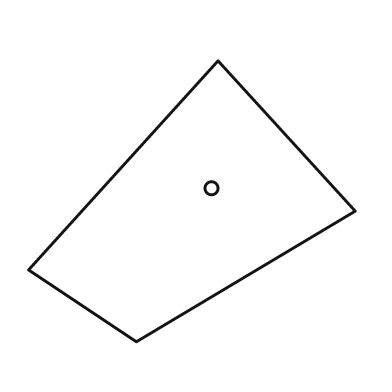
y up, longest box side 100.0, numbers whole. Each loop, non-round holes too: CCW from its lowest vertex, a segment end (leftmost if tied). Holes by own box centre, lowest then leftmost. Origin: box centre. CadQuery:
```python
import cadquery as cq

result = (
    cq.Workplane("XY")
    .moveTo(-17.0, -43.0)
    .lineTo(50.0, -3.0)
    .lineTo(8.0, 43.0)
    .lineTo(-50.0, -21.0)
    .close()
    .moveTo(6.0, 4.0)
    .circle(2.0)
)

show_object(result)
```